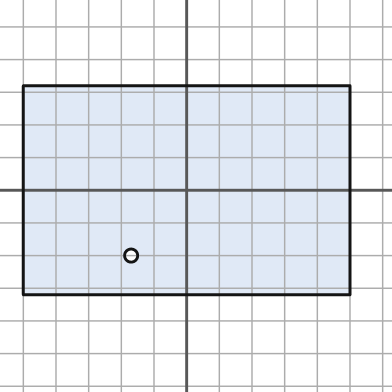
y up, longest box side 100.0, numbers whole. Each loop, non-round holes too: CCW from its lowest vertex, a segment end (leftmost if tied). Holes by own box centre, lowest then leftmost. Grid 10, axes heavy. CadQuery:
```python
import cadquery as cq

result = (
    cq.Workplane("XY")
    .moveTo(-50.0, -32.0)
    .lineTo(50.0, -32.0)
    .lineTo(50.0, 32.0)
    .lineTo(-50.0, 32.0)
    .close()
    .moveTo(-17.0, -20.0)
    .circle(2.0)
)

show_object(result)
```